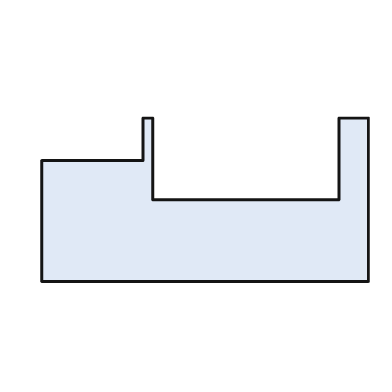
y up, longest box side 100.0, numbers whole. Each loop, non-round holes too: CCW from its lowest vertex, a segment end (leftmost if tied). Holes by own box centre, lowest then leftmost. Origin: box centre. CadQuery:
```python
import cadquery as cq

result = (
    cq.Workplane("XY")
    .moveTo(-50.0, -25.0)
    .lineTo(50.0, -25.0)
    .lineTo(50.0, 25.0)
    .lineTo(41.0, 25.0)
    .lineTo(41.0, 0.0)
    .lineTo(-16.0, 0.0)
    .lineTo(-16.0, 25.0)
    .lineTo(-19.0, 25.0)
    .lineTo(-19.0, 12.0)
    .lineTo(-50.0, 12.0)
    .close()
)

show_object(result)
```